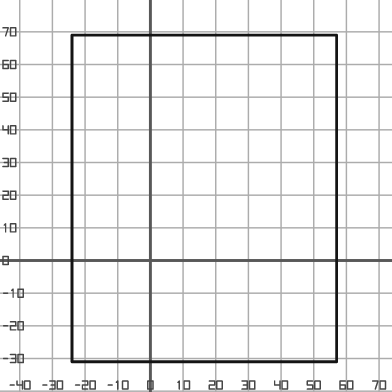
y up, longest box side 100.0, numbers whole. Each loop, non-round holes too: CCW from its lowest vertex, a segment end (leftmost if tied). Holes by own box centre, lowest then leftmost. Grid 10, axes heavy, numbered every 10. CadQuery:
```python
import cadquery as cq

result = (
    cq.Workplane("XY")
    .moveTo(-24.0, -31.0)
    .lineTo(57.0, -31.0)
    .lineTo(57.0, 69.0)
    .lineTo(-24.0, 69.0)
    .close()
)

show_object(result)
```